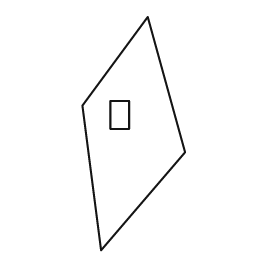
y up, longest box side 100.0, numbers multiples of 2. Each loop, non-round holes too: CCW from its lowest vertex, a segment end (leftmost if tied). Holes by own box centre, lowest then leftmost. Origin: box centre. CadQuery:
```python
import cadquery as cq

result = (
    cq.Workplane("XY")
    .moveTo(-14.0, -50.0)
    .lineTo(22.0, -8.0)
    .lineTo(6.0, 50.0)
    .lineTo(-22.0, 12.0)
    .close()
    .moveTo(-10.0, 2.0)
    .lineTo(-2.0, 2.0)
    .lineTo(-2.0, 14.0)
    .lineTo(-10.0, 14.0)
    .close()
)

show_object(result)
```